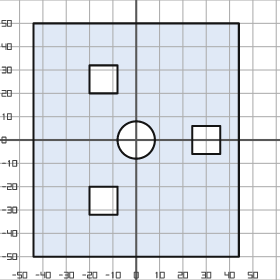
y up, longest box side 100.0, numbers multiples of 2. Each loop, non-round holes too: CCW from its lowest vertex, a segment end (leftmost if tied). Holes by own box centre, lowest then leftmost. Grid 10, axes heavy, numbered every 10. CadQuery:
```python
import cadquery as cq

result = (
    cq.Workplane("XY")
    .moveTo(-44.0, -50.0)
    .lineTo(44.0, -50.0)
    .lineTo(44.0, 50.0)
    .lineTo(-44.0, 50.0)
    .close()
    .moveTo(-20.0, -32.0)
    .lineTo(-8.0, -32.0)
    .lineTo(-8.0, -20.0)
    .lineTo(-20.0, -20.0)
    .close()
    .moveTo(0.0, 0.0)
    .circle(8.0)
    .moveTo(24.0, -6.0)
    .lineTo(36.0, -6.0)
    .lineTo(36.0, 6.0)
    .lineTo(24.0, 6.0)
    .close()
    .moveTo(-20.0, 20.0)
    .lineTo(-8.0, 20.0)
    .lineTo(-8.0, 32.0)
    .lineTo(-20.0, 32.0)
    .close()
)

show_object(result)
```